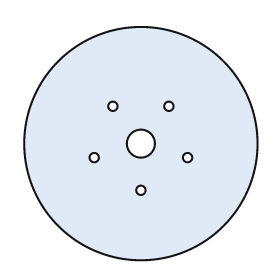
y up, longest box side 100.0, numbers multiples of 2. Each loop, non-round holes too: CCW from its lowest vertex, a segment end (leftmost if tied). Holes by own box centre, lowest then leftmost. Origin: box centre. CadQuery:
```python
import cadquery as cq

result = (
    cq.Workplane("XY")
    .moveTo(0.0, 0.0)
    .circle(50.0)
    .moveTo(0.0, -20.0)
    .circle(2.0)
    .moveTo(-20.0, -6.0)
    .circle(2.0)
    .moveTo(20.0, -6.0)
    .circle(2.0)
    .moveTo(0.0, 0.0)
    .circle(6.0)
    .moveTo(-12.0, 16.0)
    .circle(2.0)
    .moveTo(12.0, 16.0)
    .circle(2.0)
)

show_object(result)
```